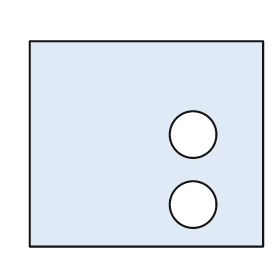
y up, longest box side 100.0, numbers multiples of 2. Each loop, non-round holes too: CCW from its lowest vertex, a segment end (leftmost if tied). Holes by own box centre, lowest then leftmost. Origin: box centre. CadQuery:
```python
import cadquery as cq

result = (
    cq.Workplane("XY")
    .moveTo(-50.0, -44.0)
    .lineTo(50.0, -44.0)
    .lineTo(50.0, 44.0)
    .lineTo(-50.0, 44.0)
    .close()
    .moveTo(20.0, -26.0)
    .circle(10.0)
    .moveTo(20.0, 4.0)
    .circle(10.0)
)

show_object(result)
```